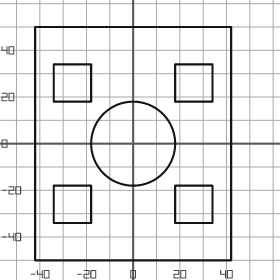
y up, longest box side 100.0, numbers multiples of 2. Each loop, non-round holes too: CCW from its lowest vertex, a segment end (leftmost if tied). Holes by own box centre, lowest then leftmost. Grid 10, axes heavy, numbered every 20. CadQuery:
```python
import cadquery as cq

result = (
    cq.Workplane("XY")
    .moveTo(-42.0, -50.0)
    .lineTo(42.0, -50.0)
    .lineTo(42.0, 50.0)
    .lineTo(-42.0, 50.0)
    .close()
    .moveTo(-34.0, -34.0)
    .lineTo(-18.0, -34.0)
    .lineTo(-18.0, -18.0)
    .lineTo(-34.0, -18.0)
    .close()
    .moveTo(18.0, -34.0)
    .lineTo(34.0, -34.0)
    .lineTo(34.0, -18.0)
    .lineTo(18.0, -18.0)
    .close()
    .moveTo(0.0, 0.0)
    .circle(18.0)
    .moveTo(-34.0, 18.0)
    .lineTo(-18.0, 18.0)
    .lineTo(-18.0, 34.0)
    .lineTo(-34.0, 34.0)
    .close()
    .moveTo(18.0, 18.0)
    .lineTo(34.0, 18.0)
    .lineTo(34.0, 34.0)
    .lineTo(18.0, 34.0)
    .close()
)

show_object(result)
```